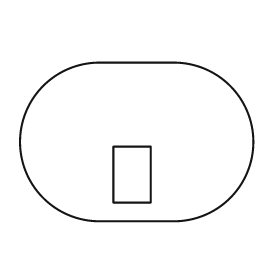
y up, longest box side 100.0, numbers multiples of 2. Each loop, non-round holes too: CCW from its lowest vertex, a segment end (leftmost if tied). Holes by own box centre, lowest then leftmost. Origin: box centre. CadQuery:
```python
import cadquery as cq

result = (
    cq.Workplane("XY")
    .moveTo(-16.0, -34.0)
    .lineTo(16.0, -34.0)
    .threePointArc((50.0, 0.0), (16.0, 34.0))
    .lineTo(-16.0, 34.0)
    .threePointArc((-50.0, 0.0), (-16.0, -34.0))
    .close()
    .moveTo(-10.0, -26.0)
    .lineTo(6.0, -26.0)
    .lineTo(6.0, -2.0)
    .lineTo(-10.0, -2.0)
    .close()
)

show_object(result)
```